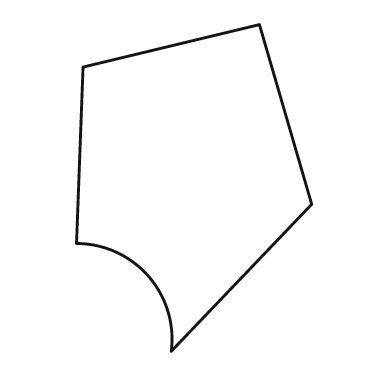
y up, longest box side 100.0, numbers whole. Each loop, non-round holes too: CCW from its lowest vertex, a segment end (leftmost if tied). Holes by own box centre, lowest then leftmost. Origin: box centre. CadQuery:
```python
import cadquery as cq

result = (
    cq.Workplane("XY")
    .moveTo(-7.0, -50.0)
    .lineTo(36.0, -5.0)
    .lineTo(20.0, 50.0)
    .lineTo(-34.0, 37.0)
    .lineTo(-36.0, -17.0)
    .threePointArc((-14.0, -27.0), (-7.0, -50.0))
    .close()
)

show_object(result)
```